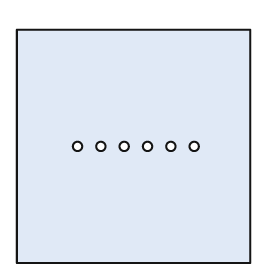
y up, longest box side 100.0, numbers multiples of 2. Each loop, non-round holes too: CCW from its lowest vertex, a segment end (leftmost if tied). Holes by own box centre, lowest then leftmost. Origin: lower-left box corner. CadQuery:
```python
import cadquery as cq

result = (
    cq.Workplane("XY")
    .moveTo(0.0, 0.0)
    .lineTo(100.0, 0.0)
    .lineTo(100.0, 100.0)
    .lineTo(0.0, 100.0)
    .close()
    .moveTo(26.0, 50.0)
    .circle(2.0)
    .moveTo(36.0, 50.0)
    .circle(2.0)
    .moveTo(46.0, 50.0)
    .circle(2.0)
    .moveTo(56.0, 50.0)
    .circle(2.0)
    .moveTo(66.0, 50.0)
    .circle(2.0)
    .moveTo(76.0, 50.0)
    .circle(2.0)
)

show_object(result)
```